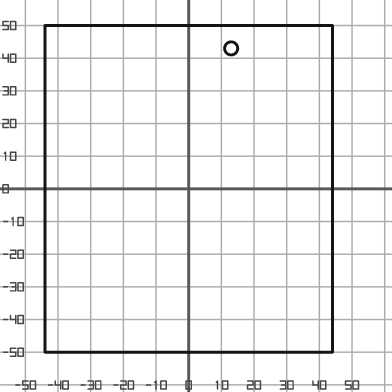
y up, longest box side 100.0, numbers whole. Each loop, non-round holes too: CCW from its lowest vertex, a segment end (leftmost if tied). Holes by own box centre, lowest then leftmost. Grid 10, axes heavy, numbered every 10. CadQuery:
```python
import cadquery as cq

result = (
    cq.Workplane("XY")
    .moveTo(-44.0, -50.0)
    .lineTo(44.0, -50.0)
    .lineTo(44.0, 50.0)
    .lineTo(-44.0, 50.0)
    .close()
    .moveTo(13.0, 43.0)
    .circle(2.0)
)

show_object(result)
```